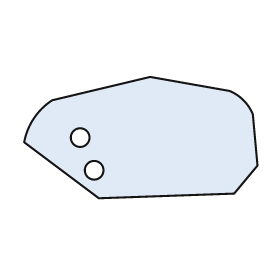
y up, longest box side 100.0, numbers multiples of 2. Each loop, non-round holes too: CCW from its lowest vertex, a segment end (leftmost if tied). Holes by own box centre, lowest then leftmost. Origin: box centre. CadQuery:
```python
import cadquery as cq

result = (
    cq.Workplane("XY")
    .moveTo(-18.0, -26.0)
    .lineTo(40.0, -24.0)
    .lineTo(50.0, -12.0)
    .lineTo(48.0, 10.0)
    .threePointArc((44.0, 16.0), (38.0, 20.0))
    .lineTo(4.0, 26.0)
    .lineTo(-38.0, 16.0)
    .threePointArc((-46.0, 8.0), (-50.0, -2.0))
    .close()
    .moveTo(-20.0, -14.0)
    .circle(4.0)
    .moveTo(-26.0, 0.0)
    .circle(4.0)
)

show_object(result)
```